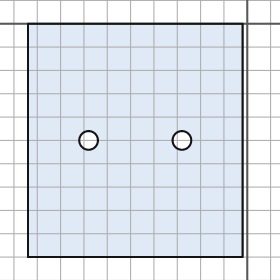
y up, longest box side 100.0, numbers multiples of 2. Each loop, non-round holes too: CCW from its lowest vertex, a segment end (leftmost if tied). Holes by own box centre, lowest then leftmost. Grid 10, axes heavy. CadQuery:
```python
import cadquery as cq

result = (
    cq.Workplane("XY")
    .moveTo(-94.0, -100.0)
    .lineTo(-2.0, -100.0)
    .lineTo(-2.0, 0.0)
    .lineTo(-94.0, 0.0)
    .close()
    .moveTo(-68.0, -50.0)
    .circle(4.0)
    .moveTo(-28.0, -50.0)
    .circle(4.0)
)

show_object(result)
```